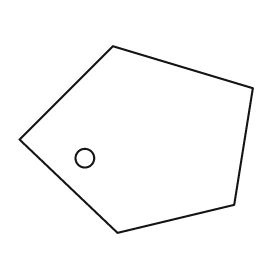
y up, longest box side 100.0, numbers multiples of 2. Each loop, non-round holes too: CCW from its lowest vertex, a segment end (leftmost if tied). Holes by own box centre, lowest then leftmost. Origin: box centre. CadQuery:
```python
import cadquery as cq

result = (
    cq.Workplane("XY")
    .moveTo(-8.0, -40.0)
    .lineTo(42.0, -28.0)
    .lineTo(50.0, 22.0)
    .lineTo(-10.0, 40.0)
    .lineTo(-50.0, 0.0)
    .close()
    .moveTo(-22.0, -8.0)
    .circle(4.0)
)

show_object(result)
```